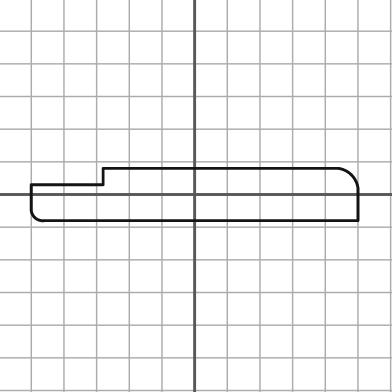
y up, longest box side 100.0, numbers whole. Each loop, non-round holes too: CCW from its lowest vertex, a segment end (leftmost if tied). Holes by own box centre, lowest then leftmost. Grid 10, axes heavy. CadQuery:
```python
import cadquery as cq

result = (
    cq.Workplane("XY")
    .moveTo(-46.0, -8.0)
    .lineTo(50.0, -8.0)
    .lineTo(50.0, 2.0)
    .threePointArc((48.0, 6.0), (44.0, 8.0))
    .lineTo(-28.0, 8.0)
    .lineTo(-28.0, 3.0)
    .lineTo(-50.0, 3.0)
    .lineTo(-50.0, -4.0)
    .threePointArc((-49.0, -7.0), (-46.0, -8.0))
    .close()
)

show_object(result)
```